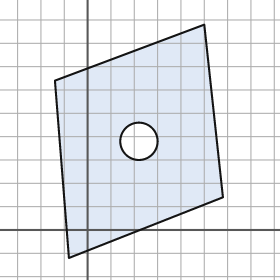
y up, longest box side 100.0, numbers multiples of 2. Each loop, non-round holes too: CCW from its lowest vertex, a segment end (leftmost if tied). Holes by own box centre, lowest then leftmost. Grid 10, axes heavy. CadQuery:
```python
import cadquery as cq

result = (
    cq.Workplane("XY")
    .moveTo(-8.0, -12.0)
    .lineTo(58.0, 14.0)
    .lineTo(50.0, 88.0)
    .lineTo(-14.0, 64.0)
    .close()
    .moveTo(22.0, 38.0)
    .circle(8.0)
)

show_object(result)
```